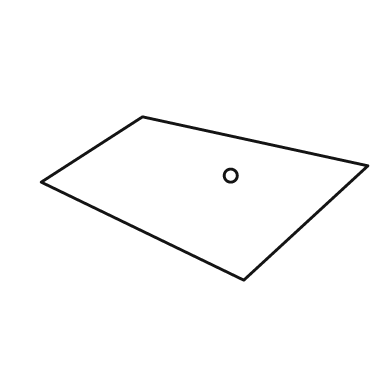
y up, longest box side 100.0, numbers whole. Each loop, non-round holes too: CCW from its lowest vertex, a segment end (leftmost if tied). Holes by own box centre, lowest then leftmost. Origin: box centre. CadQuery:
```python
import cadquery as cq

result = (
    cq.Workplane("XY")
    .moveTo(12.0, -25.0)
    .lineTo(50.0, 10.0)
    .lineTo(-19.0, 25.0)
    .lineTo(-50.0, 5.0)
    .close()
    .moveTo(8.0, 7.0)
    .circle(2.0)
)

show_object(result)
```